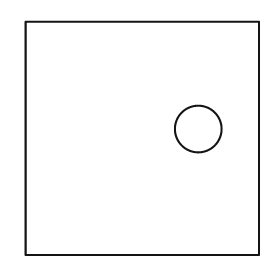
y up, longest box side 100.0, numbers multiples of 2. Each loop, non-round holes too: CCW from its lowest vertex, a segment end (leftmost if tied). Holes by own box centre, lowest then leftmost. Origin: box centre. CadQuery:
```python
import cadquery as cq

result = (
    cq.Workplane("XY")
    .moveTo(-50.0, -50.0)
    .lineTo(50.0, -50.0)
    .lineTo(50.0, 50.0)
    .lineTo(-50.0, 50.0)
    .close()
    .moveTo(24.0, 4.0)
    .circle(10.0)
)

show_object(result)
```